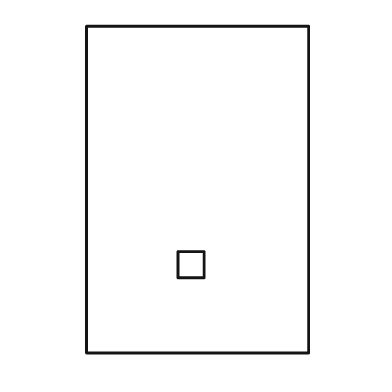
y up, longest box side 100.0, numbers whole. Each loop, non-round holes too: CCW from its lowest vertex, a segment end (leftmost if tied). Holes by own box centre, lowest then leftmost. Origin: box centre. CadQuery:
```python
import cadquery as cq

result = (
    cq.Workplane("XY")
    .moveTo(-34.0, -50.0)
    .lineTo(34.0, -50.0)
    .lineTo(34.0, 50.0)
    .lineTo(-34.0, 50.0)
    .close()
    .moveTo(-6.0, -27.0)
    .lineTo(2.0, -27.0)
    .lineTo(2.0, -19.0)
    .lineTo(-6.0, -19.0)
    .close()
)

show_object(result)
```